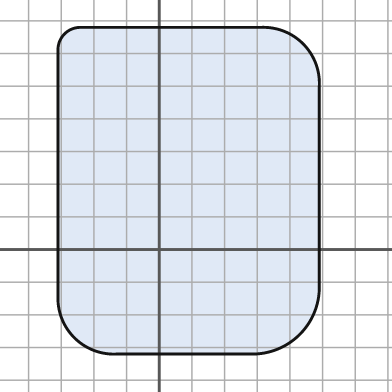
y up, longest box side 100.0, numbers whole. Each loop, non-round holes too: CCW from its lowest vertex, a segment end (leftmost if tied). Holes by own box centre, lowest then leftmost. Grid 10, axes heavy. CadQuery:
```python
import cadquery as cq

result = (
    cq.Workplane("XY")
    .moveTo(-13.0, -32.0)
    .lineTo(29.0, -32.0)
    .threePointArc((43.0, -26.0), (49.0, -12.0))
    .lineTo(49.0, 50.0)
    .threePointArc((44.0, 63.0), (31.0, 68.0))
    .lineTo(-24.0, 68.0)
    .threePointArc((-29.0, 66.0), (-31.0, 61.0))
    .lineTo(-31.0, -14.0)
    .threePointArc((-26.0, -27.0), (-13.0, -32.0))
    .close()
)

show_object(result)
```